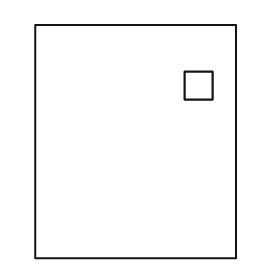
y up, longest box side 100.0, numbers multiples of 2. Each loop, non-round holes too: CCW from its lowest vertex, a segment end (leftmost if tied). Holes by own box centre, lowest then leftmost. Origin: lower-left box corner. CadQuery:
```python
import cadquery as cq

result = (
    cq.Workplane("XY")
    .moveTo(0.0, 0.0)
    .lineTo(86.0, 0.0)
    .lineTo(86.0, 100.0)
    .lineTo(0.0, 100.0)
    .close()
    .moveTo(64.0, 68.0)
    .lineTo(76.0, 68.0)
    .lineTo(76.0, 80.0)
    .lineTo(64.0, 80.0)
    .close()
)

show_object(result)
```